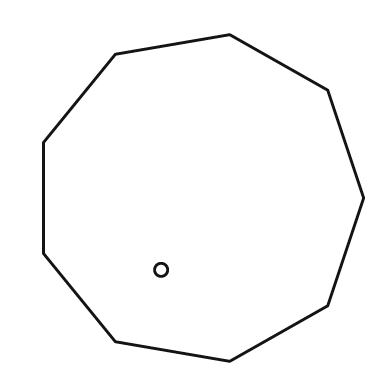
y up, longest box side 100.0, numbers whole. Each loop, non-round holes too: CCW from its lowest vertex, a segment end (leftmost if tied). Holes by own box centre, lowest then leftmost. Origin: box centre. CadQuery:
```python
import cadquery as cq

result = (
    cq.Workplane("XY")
    .moveTo(8.0, -50.0)
    .lineTo(38.0, -33.0)
    .lineTo(49.0, 0.0)
    .lineTo(38.0, 33.0)
    .lineTo(8.0, 50.0)
    .lineTo(-27.0, 44.0)
    .lineTo(-49.0, 17.0)
    .lineTo(-49.0, -17.0)
    .lineTo(-27.0, -44.0)
    .close()
    .moveTo(-13.0, -22.0)
    .circle(2.0)
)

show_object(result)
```